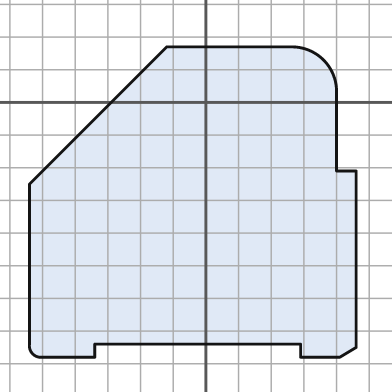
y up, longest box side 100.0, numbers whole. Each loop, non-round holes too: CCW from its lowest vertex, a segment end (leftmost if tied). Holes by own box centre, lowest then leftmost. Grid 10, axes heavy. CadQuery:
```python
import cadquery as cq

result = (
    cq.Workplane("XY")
    .moveTo(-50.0, -78.0)
    .lineTo(-34.0, -78.0)
    .lineTo(-34.0, -74.0)
    .lineTo(29.0, -74.0)
    .lineTo(29.0, -78.0)
    .lineTo(41.0, -78.0)
    .lineTo(46.0, -75.0)
    .lineTo(46.0, -21.0)
    .lineTo(40.0, -21.0)
    .lineTo(40.0, 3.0)
    .threePointArc((36.0, 13.0), (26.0, 17.0))
    .lineTo(-12.0, 17.0)
    .lineTo(-54.0, -25.0)
    .lineTo(-54.0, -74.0)
    .threePointArc((-53.0, -77.0), (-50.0, -78.0))
    .close()
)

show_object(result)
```